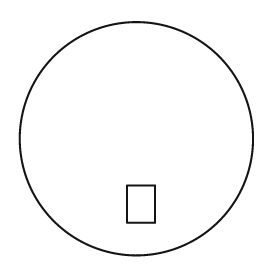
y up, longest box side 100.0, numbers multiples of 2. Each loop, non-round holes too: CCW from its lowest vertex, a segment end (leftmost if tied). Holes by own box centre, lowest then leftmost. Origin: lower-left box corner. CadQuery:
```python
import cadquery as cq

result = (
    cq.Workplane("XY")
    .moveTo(50.0, 50.0)
    .circle(50.0)
    .moveTo(46.0, 14.0)
    .lineTo(58.0, 14.0)
    .lineTo(58.0, 30.0)
    .lineTo(46.0, 30.0)
    .close()
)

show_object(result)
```